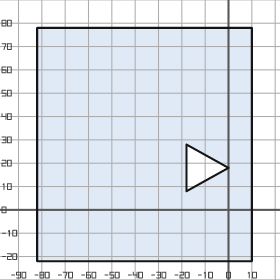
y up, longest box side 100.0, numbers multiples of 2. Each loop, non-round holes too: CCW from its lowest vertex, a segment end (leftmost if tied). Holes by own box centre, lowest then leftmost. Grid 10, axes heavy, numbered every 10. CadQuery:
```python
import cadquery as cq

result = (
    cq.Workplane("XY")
    .moveTo(-82.0, -22.0)
    .lineTo(10.0, -22.0)
    .lineTo(10.0, 78.0)
    .lineTo(-82.0, 78.0)
    .close()
    .moveTo(-18.0, 8.0)
    .lineTo(0.0, 18.0)
    .lineTo(-18.0, 28.0)
    .close()
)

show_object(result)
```